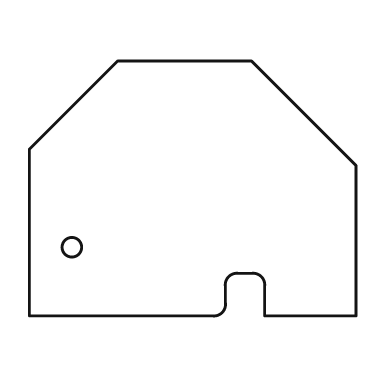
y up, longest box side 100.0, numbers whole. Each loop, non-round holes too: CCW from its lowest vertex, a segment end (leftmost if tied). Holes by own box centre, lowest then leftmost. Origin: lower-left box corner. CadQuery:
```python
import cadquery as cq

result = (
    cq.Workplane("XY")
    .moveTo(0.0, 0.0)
    .lineTo(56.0, 0.0)
    .threePointArc((59.0, 1.0), (60.0, 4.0))
    .lineTo(60.0, 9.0)
    .threePointArc((61.0, 12.0), (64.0, 13.0))
    .lineTo(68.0, 13.0)
    .threePointArc((71.0, 12.0), (72.0, 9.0))
    .lineTo(72.0, 0.0)
    .lineTo(100.0, 0.0)
    .lineTo(100.0, 46.0)
    .lineTo(68.0, 78.0)
    .lineTo(27.0, 78.0)
    .lineTo(0.0, 51.0)
    .close()
    .moveTo(13.0, 21.0)
    .circle(3.0)
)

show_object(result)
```